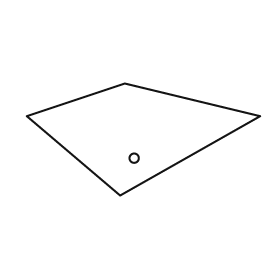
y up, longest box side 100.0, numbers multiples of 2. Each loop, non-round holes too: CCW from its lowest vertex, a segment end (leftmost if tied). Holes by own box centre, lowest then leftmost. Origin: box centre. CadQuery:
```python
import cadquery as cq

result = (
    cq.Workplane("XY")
    .moveTo(-10.0, -24.0)
    .lineTo(50.0, 10.0)
    .lineTo(-8.0, 24.0)
    .lineTo(-50.0, 10.0)
    .close()
    .moveTo(-4.0, -8.0)
    .circle(2.0)
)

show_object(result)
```